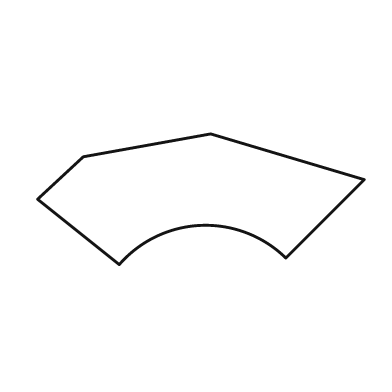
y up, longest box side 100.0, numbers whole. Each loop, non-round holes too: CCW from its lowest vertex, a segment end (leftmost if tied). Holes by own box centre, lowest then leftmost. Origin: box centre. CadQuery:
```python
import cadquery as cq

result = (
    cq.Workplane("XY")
    .moveTo(-25.0, -20.0)
    .threePointArc((0.0, -8.0), (26.0, -18.0))
    .lineTo(50.0, 6.0)
    .lineTo(3.0, 20.0)
    .lineTo(-36.0, 13.0)
    .lineTo(-50.0, 0.0)
    .close()
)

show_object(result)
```